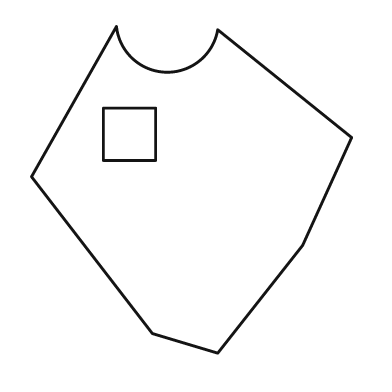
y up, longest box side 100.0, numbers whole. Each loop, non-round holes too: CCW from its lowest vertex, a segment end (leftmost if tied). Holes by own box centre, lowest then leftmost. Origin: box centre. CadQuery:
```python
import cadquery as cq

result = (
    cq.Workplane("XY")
    .moveTo(8.0, -50.0)
    .lineTo(34.0, -17.0)
    .lineTo(49.0, 16.0)
    .lineTo(8.0, 49.0)
    .threePointArc((-8.0, 36.0), (-23.0, 50.0))
    .lineTo(-49.0, 4.0)
    .lineTo(-12.0, -44.0)
    .close()
    .moveTo(-27.0, 9.0)
    .lineTo(-11.0, 9.0)
    .lineTo(-11.0, 25.0)
    .lineTo(-27.0, 25.0)
    .close()
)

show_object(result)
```